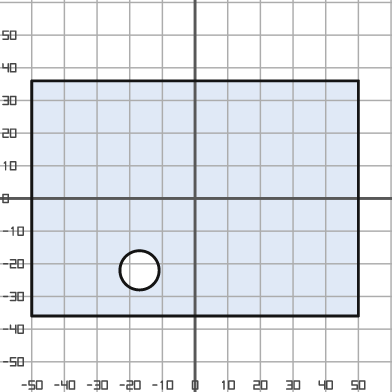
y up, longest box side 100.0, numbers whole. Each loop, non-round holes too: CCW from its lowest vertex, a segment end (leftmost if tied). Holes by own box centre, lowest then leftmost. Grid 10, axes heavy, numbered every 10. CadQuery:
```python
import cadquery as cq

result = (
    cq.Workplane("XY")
    .moveTo(-50.0, -36.0)
    .lineTo(50.0, -36.0)
    .lineTo(50.0, 36.0)
    .lineTo(-50.0, 36.0)
    .close()
    .moveTo(-17.0, -22.0)
    .circle(6.0)
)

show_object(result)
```